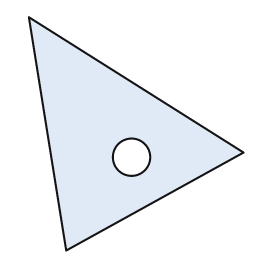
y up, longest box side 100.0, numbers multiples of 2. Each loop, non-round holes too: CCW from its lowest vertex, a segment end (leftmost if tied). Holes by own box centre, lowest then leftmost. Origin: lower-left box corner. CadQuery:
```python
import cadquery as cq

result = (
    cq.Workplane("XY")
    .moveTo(16.0, 0.0)
    .lineTo(92.0, 42.0)
    .lineTo(0.0, 100.0)
    .close()
    .moveTo(44.0, 40.0)
    .circle(8.0)
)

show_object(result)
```